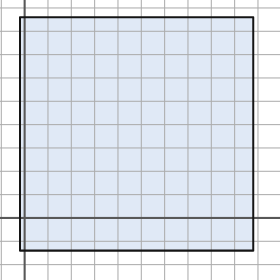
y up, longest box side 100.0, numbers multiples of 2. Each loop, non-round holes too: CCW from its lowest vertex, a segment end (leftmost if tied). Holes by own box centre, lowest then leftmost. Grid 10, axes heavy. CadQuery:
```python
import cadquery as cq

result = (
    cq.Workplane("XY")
    .moveTo(-2.0, -14.0)
    .lineTo(98.0, -14.0)
    .lineTo(98.0, 86.0)
    .lineTo(-2.0, 86.0)
    .close()
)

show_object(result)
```